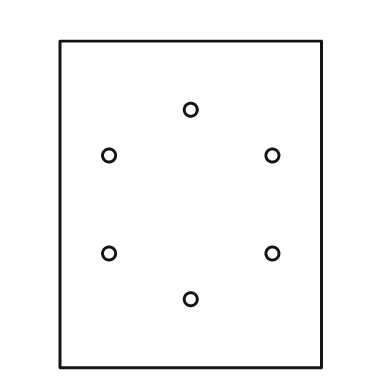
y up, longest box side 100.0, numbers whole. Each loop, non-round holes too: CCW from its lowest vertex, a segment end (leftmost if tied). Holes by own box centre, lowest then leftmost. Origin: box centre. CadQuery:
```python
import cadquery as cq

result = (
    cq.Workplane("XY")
    .moveTo(-40.0, -50.0)
    .lineTo(40.0, -50.0)
    .lineTo(40.0, 50.0)
    .lineTo(-40.0, 50.0)
    .close()
    .moveTo(0.0, -29.0)
    .circle(2.0)
    .moveTo(-25.0, -15.0)
    .circle(2.0)
    .moveTo(25.0, -15.0)
    .circle(2.0)
    .moveTo(-25.0, 15.0)
    .circle(2.0)
    .moveTo(25.0, 15.0)
    .circle(2.0)
    .moveTo(0.0, 29.0)
    .circle(2.0)
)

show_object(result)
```